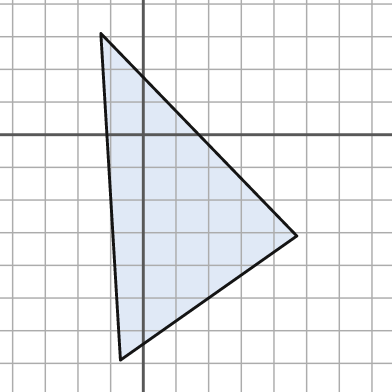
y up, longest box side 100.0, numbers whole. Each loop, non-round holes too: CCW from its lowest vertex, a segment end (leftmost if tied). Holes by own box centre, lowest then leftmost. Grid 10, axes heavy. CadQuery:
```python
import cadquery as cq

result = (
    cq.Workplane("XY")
    .moveTo(-7.0, -69.0)
    .lineTo(47.0, -31.0)
    .lineTo(-13.0, 31.0)
    .close()
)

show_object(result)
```